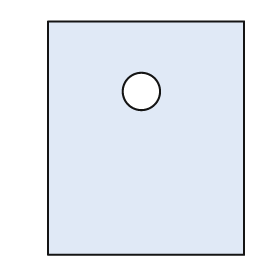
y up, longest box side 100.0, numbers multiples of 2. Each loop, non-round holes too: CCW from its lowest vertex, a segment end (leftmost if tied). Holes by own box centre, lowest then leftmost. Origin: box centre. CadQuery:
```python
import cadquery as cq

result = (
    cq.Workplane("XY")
    .moveTo(-42.0, -50.0)
    .lineTo(42.0, -50.0)
    .lineTo(42.0, 50.0)
    .lineTo(-42.0, 50.0)
    .close()
    .moveTo(-2.0, 20.0)
    .circle(8.0)
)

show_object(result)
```